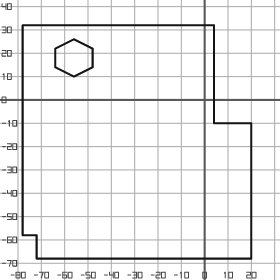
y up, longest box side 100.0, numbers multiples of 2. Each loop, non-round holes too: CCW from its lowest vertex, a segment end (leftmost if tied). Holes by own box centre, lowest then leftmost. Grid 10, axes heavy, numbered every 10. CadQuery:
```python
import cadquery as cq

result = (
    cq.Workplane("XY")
    .moveTo(-72.0, -68.0)
    .lineTo(20.0, -68.0)
    .lineTo(20.0, -10.0)
    .lineTo(4.0, -10.0)
    .lineTo(4.0, 32.0)
    .lineTo(-78.0, 32.0)
    .lineTo(-78.0, -58.0)
    .lineTo(-72.0, -58.0)
    .close()
    .moveTo(-56.0, 10.0)
    .lineTo(-48.0, 14.0)
    .lineTo(-48.0, 22.0)
    .lineTo(-56.0, 26.0)
    .lineTo(-64.0, 22.0)
    .lineTo(-64.0, 14.0)
    .close()
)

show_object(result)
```